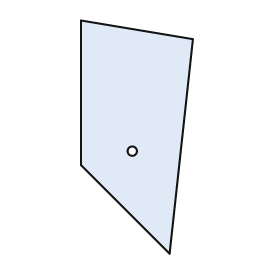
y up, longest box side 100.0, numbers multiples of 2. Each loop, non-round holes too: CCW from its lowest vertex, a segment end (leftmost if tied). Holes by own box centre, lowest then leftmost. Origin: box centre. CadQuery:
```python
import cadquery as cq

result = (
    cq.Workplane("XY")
    .moveTo(14.0, -50.0)
    .lineTo(24.0, 42.0)
    .lineTo(-24.0, 50.0)
    .lineTo(-24.0, -12.0)
    .close()
    .moveTo(-2.0, -6.0)
    .circle(2.0)
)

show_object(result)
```